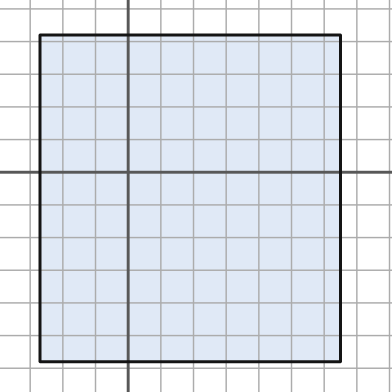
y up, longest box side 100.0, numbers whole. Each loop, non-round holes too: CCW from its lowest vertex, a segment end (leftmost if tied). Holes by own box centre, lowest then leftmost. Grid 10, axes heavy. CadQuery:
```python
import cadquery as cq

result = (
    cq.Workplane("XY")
    .moveTo(-27.0, -58.0)
    .lineTo(65.0, -58.0)
    .lineTo(65.0, 42.0)
    .lineTo(-27.0, 42.0)
    .close()
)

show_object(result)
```